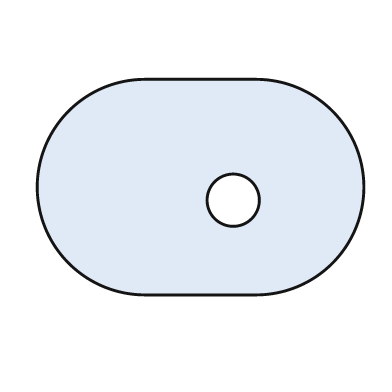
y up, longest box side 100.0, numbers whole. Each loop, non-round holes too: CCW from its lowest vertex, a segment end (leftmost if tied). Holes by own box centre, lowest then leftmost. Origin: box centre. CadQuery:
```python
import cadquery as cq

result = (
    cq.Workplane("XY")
    .moveTo(-17.0, -33.0)
    .lineTo(17.0, -33.0)
    .threePointArc((50.0, 0.0), (17.0, 33.0))
    .lineTo(-17.0, 33.0)
    .threePointArc((-50.0, 0.0), (-17.0, -33.0))
    .close()
    .moveTo(10.0, -4.0)
    .circle(8.0)
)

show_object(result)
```